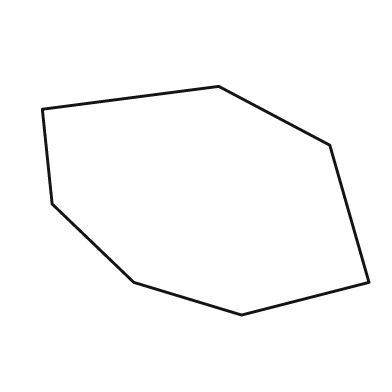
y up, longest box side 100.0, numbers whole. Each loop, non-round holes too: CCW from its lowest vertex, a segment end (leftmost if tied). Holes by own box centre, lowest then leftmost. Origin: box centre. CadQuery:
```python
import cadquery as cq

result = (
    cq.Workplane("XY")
    .moveTo(11.0, -35.0)
    .lineTo(50.0, -25.0)
    .lineTo(38.0, 17.0)
    .lineTo(4.0, 35.0)
    .lineTo(-50.0, 28.0)
    .lineTo(-47.0, -1.0)
    .lineTo(-22.0, -25.0)
    .close()
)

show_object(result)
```